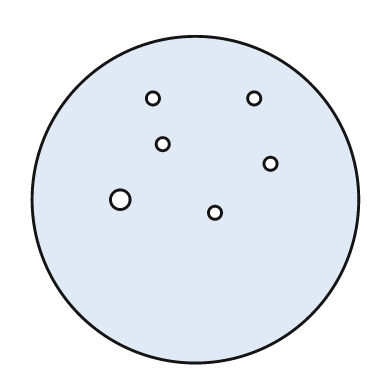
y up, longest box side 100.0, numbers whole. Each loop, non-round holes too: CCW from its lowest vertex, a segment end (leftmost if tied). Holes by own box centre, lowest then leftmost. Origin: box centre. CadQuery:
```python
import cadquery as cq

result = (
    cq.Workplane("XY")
    .moveTo(0.0, 0.0)
    .circle(50.0)
    .moveTo(6.0, -4.0)
    .circle(2.0)
    .moveTo(-23.0, 0.0)
    .circle(3.0)
    .moveTo(23.0, 11.0)
    .circle(2.0)
    .moveTo(-10.0, 17.0)
    .circle(2.0)
    .moveTo(-13.0, 31.0)
    .circle(2.0)
    .moveTo(18.0, 31.0)
    .circle(2.0)
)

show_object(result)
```